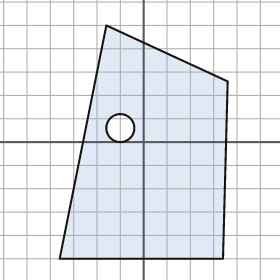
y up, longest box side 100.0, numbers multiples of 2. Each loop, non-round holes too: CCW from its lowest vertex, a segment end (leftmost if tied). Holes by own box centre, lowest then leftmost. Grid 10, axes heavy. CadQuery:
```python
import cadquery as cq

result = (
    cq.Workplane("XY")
    .moveTo(-36.0, -50.0)
    .lineTo(34.0, -50.0)
    .lineTo(36.0, 26.0)
    .lineTo(-16.0, 50.0)
    .close()
    .moveTo(-10.0, 6.0)
    .circle(6.0)
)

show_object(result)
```